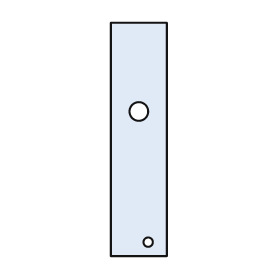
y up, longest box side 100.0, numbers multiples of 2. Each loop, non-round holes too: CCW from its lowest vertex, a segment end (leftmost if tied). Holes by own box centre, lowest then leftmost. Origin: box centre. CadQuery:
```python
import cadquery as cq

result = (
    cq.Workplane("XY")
    .moveTo(-12.0, -50.0)
    .lineTo(12.0, -50.0)
    .lineTo(12.0, 50.0)
    .lineTo(-12.0, 50.0)
    .close()
    .moveTo(4.0, -44.0)
    .circle(2.0)
    .moveTo(0.0, 12.0)
    .circle(4.0)
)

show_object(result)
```